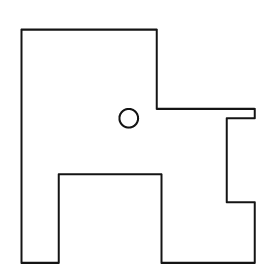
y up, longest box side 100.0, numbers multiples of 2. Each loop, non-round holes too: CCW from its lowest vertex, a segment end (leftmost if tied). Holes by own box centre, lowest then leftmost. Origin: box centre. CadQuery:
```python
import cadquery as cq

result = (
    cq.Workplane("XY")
    .moveTo(-50.0, -50.0)
    .lineTo(-34.0, -50.0)
    .lineTo(-34.0, -12.0)
    .lineTo(10.0, -12.0)
    .lineTo(10.0, -50.0)
    .lineTo(50.0, -50.0)
    .lineTo(50.0, -24.0)
    .lineTo(38.0, -24.0)
    .lineTo(38.0, 12.0)
    .lineTo(50.0, 12.0)
    .lineTo(50.0, 16.0)
    .lineTo(8.0, 16.0)
    .lineTo(8.0, 50.0)
    .lineTo(-50.0, 50.0)
    .close()
    .moveTo(-4.0, 12.0)
    .circle(4.0)
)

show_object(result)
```